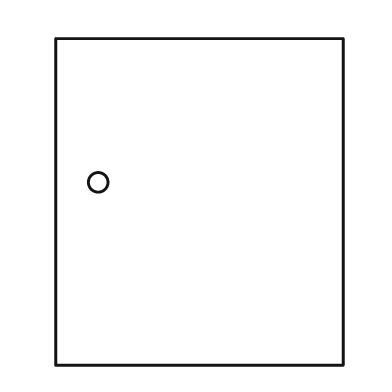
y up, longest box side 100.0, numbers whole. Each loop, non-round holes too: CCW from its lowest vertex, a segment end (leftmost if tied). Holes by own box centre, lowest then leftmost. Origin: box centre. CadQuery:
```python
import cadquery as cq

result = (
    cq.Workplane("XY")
    .moveTo(-44.0, -50.0)
    .lineTo(44.0, -50.0)
    .lineTo(44.0, 50.0)
    .lineTo(-44.0, 50.0)
    .close()
    .moveTo(-31.0, 6.0)
    .circle(3.0)
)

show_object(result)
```